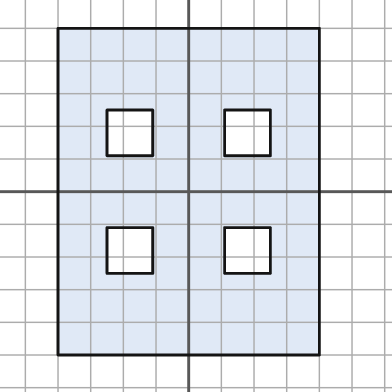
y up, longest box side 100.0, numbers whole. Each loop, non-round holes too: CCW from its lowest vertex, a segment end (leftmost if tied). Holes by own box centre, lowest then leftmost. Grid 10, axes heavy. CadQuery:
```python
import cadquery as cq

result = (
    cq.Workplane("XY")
    .moveTo(-40.0, -50.0)
    .lineTo(40.0, -50.0)
    .lineTo(40.0, 50.0)
    .lineTo(-40.0, 50.0)
    .close()
    .moveTo(-25.0, -25.0)
    .lineTo(-11.0, -25.0)
    .lineTo(-11.0, -11.0)
    .lineTo(-25.0, -11.0)
    .close()
    .moveTo(11.0, -25.0)
    .lineTo(25.0, -25.0)
    .lineTo(25.0, -11.0)
    .lineTo(11.0, -11.0)
    .close()
    .moveTo(-25.0, 11.0)
    .lineTo(-11.0, 11.0)
    .lineTo(-11.0, 25.0)
    .lineTo(-25.0, 25.0)
    .close()
    .moveTo(11.0, 11.0)
    .lineTo(25.0, 11.0)
    .lineTo(25.0, 25.0)
    .lineTo(11.0, 25.0)
    .close()
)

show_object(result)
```